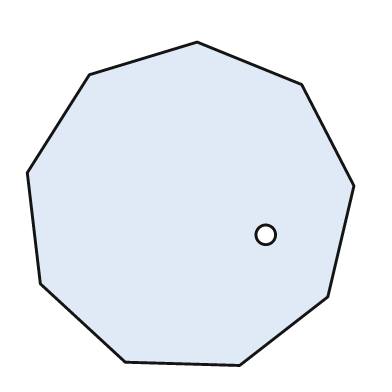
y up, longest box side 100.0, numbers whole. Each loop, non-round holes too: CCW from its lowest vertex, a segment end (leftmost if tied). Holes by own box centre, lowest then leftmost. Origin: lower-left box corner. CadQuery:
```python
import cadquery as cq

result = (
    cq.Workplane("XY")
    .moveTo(65.0, 0.0)
    .lineTo(92.0, 21.0)
    .lineTo(100.0, 55.0)
    .lineTo(84.0, 86.0)
    .lineTo(52.0, 99.0)
    .lineTo(19.0, 89.0)
    .lineTo(0.0, 59.0)
    .lineTo(4.0, 25.0)
    .lineTo(30.0, 1.0)
    .close()
    .moveTo(73.0, 40.0)
    .circle(3.0)
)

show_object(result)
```